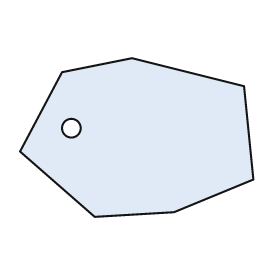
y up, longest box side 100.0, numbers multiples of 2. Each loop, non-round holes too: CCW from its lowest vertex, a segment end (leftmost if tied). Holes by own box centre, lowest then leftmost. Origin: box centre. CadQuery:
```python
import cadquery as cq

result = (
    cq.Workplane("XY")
    .moveTo(-18.0, -34.0)
    .lineTo(16.0, -32.0)
    .lineTo(50.0, -18.0)
    .lineTo(46.0, 22.0)
    .lineTo(-2.0, 34.0)
    .lineTo(-32.0, 28.0)
    .lineTo(-50.0, -6.0)
    .close()
    .moveTo(-28.0, 4.0)
    .circle(4.0)
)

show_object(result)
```